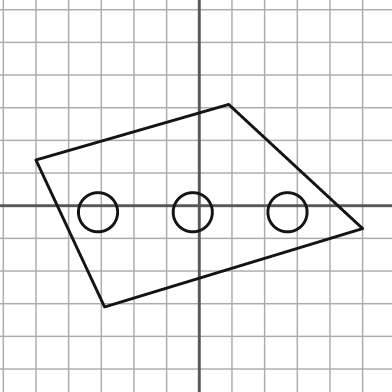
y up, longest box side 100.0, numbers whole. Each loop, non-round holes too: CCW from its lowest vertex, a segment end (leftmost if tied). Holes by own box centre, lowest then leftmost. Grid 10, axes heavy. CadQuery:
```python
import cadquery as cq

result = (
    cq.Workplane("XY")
    .moveTo(-29.0, -31.0)
    .lineTo(50.0, -7.0)
    .lineTo(9.0, 31.0)
    .lineTo(-50.0, 14.0)
    .close()
    .moveTo(-31.0, -2.0)
    .circle(6.0)
    .moveTo(-2.0, -2.0)
    .circle(6.0)
    .moveTo(27.0, -2.0)
    .circle(6.0)
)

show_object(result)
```